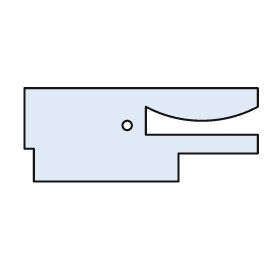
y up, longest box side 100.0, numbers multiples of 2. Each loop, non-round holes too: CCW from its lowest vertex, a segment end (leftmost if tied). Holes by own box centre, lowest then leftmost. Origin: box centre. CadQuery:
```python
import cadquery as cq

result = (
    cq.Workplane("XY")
    .moveTo(-46.0, -20.0)
    .lineTo(16.0, -20.0)
    .lineTo(16.0, -8.0)
    .lineTo(50.0, -8.0)
    .lineTo(50.0, 0.0)
    .lineTo(2.0, 0.0)
    .lineTo(2.0, 12.0)
    .threePointArc((26.0, 6.0), (50.0, 12.0))
    .lineTo(50.0, 20.0)
    .lineTo(-50.0, 20.0)
    .lineTo(-50.0, -6.0)
    .lineTo(-46.0, -6.0)
    .close()
    .moveTo(-6.0, 4.0)
    .circle(2.0)
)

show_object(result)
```